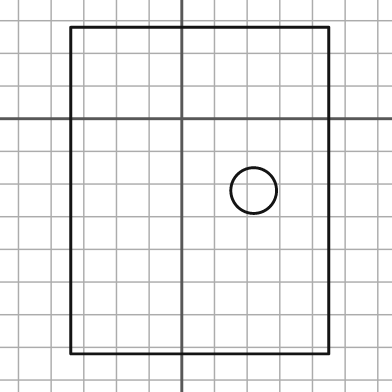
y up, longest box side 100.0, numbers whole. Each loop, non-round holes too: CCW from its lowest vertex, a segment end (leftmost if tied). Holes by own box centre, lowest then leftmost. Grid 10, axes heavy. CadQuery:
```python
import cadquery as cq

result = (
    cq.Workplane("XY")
    .moveTo(-34.0, -72.0)
    .lineTo(45.0, -72.0)
    .lineTo(45.0, 28.0)
    .lineTo(-34.0, 28.0)
    .close()
    .moveTo(22.0, -22.0)
    .circle(7.0)
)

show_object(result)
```